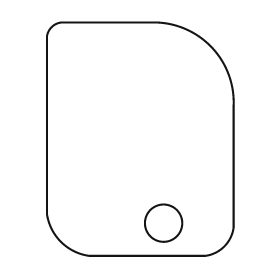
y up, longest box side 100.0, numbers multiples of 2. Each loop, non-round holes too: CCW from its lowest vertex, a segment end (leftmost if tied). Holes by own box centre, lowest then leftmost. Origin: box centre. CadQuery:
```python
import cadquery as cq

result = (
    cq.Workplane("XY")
    .moveTo(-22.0, -50.0)
    .lineTo(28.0, -50.0)
    .threePointArc((36.0, -46.0), (40.0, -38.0))
    .lineTo(40.0, 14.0)
    .threePointArc((30.0, 40.0), (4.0, 50.0))
    .lineTo(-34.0, 50.0)
    .threePointArc((-38.0, 48.0), (-40.0, 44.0))
    .lineTo(-40.0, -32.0)
    .threePointArc((-34.0, -44.0), (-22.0, -50.0))
    .close()
    .moveTo(10.0, -36.0)
    .circle(8.0)
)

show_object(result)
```